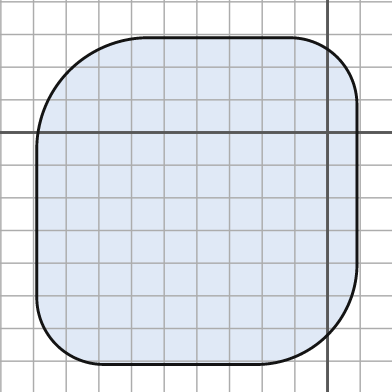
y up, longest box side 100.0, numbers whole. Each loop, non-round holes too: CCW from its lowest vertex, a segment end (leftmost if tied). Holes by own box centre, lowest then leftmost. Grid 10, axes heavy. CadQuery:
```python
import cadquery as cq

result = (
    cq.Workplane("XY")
    .moveTo(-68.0, -71.0)
    .lineTo(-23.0, -71.0)
    .threePointArc((0.0, -62.0), (9.0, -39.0))
    .lineTo(9.0, 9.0)
    .threePointArc((3.0, 23.0), (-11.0, 29.0))
    .lineTo(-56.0, 29.0)
    .threePointArc((-79.0, 19.0), (-89.0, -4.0))
    .lineTo(-89.0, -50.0)
    .threePointArc((-83.0, -65.0), (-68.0, -71.0))
    .close()
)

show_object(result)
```